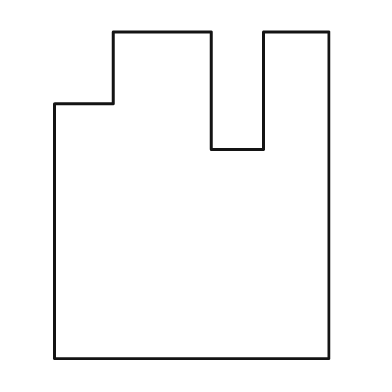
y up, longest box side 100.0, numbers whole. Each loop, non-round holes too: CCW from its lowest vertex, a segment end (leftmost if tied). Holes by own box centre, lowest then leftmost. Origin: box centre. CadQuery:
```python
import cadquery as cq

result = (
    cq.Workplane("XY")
    .moveTo(-42.0, -50.0)
    .lineTo(42.0, -50.0)
    .lineTo(42.0, 50.0)
    .lineTo(22.0, 50.0)
    .lineTo(22.0, 14.0)
    .lineTo(6.0, 14.0)
    .lineTo(6.0, 50.0)
    .lineTo(-24.0, 50.0)
    .lineTo(-24.0, 28.0)
    .lineTo(-42.0, 28.0)
    .close()
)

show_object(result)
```